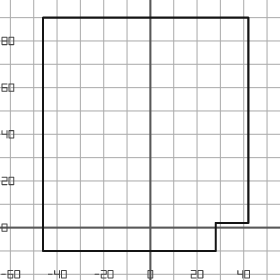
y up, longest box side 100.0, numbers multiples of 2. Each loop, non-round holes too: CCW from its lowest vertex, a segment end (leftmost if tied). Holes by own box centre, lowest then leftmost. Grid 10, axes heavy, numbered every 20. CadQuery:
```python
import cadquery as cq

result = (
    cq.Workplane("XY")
    .moveTo(-46.0, -10.0)
    .lineTo(28.0, -10.0)
    .lineTo(28.0, 2.0)
    .lineTo(42.0, 2.0)
    .lineTo(42.0, 90.0)
    .lineTo(-46.0, 90.0)
    .close()
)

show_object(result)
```